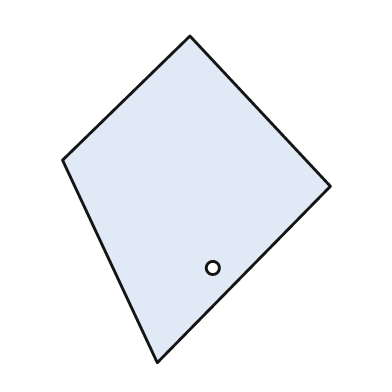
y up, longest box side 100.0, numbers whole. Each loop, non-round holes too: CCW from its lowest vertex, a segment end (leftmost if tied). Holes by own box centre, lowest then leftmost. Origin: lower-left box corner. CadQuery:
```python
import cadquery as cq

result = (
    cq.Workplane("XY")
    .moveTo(29.0, 0.0)
    .lineTo(82.0, 54.0)
    .lineTo(39.0, 100.0)
    .lineTo(0.0, 62.0)
    .close()
    .moveTo(46.0, 29.0)
    .circle(2.0)
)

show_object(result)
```